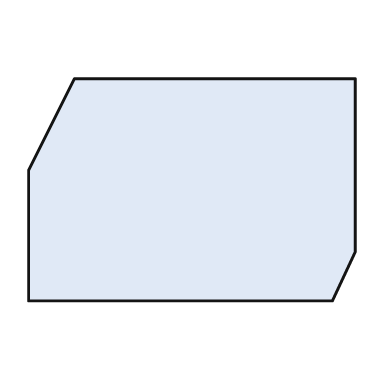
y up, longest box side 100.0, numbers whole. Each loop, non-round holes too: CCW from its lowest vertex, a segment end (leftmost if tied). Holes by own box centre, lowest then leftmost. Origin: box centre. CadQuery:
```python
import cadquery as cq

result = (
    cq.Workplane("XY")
    .moveTo(-50.0, -34.0)
    .lineTo(43.0, -34.0)
    .lineTo(50.0, -19.0)
    .lineTo(50.0, 34.0)
    .lineTo(-36.0, 34.0)
    .lineTo(-50.0, 6.0)
    .close()
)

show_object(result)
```